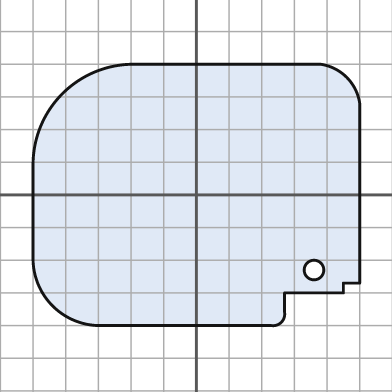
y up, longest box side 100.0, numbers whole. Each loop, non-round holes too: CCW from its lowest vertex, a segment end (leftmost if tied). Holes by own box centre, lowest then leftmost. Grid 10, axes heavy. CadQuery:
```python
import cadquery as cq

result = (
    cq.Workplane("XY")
    .moveTo(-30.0, -40.0)
    .lineTo(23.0, -40.0)
    .threePointArc((26.0, -39.0), (27.0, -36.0))
    .lineTo(27.0, -30.0)
    .lineTo(45.0, -30.0)
    .lineTo(45.0, -27.0)
    .lineTo(50.0, -27.0)
    .lineTo(50.0, 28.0)
    .threePointArc((46.0, 36.0), (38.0, 40.0))
    .lineTo(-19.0, 40.0)
    .threePointArc((-41.0, 31.0), (-50.0, 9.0))
    .lineTo(-50.0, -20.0)
    .threePointArc((-44.0, -34.0), (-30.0, -40.0))
    .close()
    .moveTo(36.0, -23.0)
    .circle(3.0)
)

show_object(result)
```